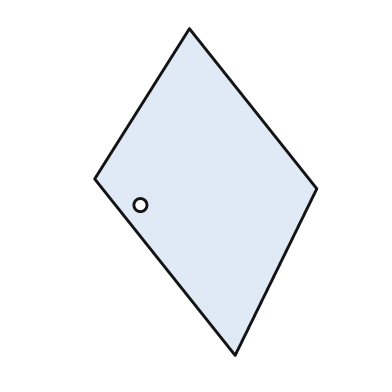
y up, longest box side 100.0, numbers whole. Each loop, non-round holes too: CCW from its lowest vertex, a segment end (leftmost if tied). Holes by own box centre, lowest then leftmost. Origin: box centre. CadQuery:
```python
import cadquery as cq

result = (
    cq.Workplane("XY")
    .moveTo(9.0, -50.0)
    .lineTo(34.0, 1.0)
    .lineTo(-5.0, 50.0)
    .lineTo(-34.0, 4.0)
    .close()
    .moveTo(-20.0, -4.0)
    .circle(2.0)
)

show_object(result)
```